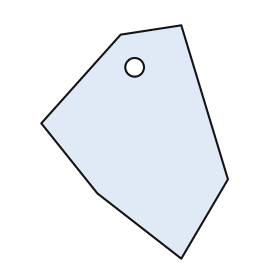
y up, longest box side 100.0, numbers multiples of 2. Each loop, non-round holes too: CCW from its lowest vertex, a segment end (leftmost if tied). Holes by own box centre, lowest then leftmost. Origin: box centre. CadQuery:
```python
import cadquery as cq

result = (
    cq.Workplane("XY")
    .moveTo(20.0, -50.0)
    .lineTo(40.0, -16.0)
    .lineTo(20.0, 50.0)
    .lineTo(-6.0, 46.0)
    .lineTo(-40.0, 8.0)
    .lineTo(-16.0, -22.0)
    .close()
    .moveTo(0.0, 32.0)
    .circle(4.0)
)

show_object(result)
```